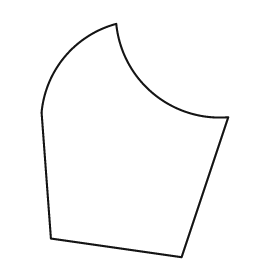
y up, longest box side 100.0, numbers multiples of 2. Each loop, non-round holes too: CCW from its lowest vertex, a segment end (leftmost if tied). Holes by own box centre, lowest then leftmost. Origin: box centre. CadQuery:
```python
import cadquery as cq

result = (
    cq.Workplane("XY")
    .moveTo(20.0, -50.0)
    .lineTo(40.0, 10.0)
    .threePointArc((8.0, 20.0), (-8.0, 50.0))
    .threePointArc((-30.0, 36.0), (-40.0, 12.0))
    .lineTo(-36.0, -42.0)
    .close()
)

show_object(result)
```